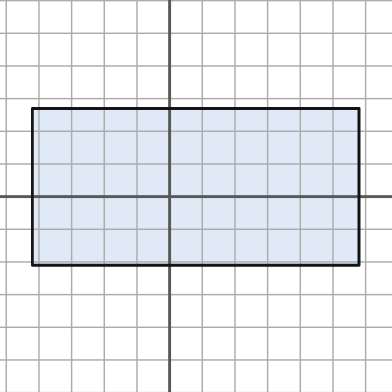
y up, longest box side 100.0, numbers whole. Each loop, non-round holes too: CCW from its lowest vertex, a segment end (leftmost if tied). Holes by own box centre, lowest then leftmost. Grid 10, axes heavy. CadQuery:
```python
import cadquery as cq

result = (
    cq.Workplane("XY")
    .moveTo(-42.0, -21.0)
    .lineTo(58.0, -21.0)
    .lineTo(58.0, 27.0)
    .lineTo(-42.0, 27.0)
    .close()
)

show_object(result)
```